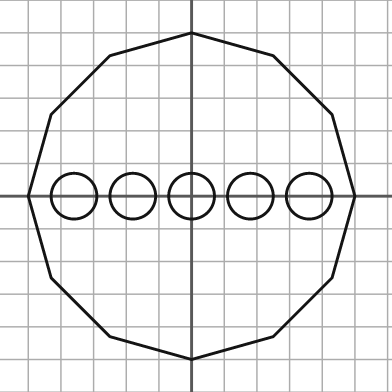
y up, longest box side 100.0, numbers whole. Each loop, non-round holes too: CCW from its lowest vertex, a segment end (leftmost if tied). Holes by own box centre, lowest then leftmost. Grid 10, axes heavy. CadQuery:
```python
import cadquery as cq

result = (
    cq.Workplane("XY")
    .moveTo(0.0, -50.0)
    .lineTo(25.0, -43.0)
    .lineTo(43.0, -25.0)
    .lineTo(50.0, 0.0)
    .lineTo(43.0, 25.0)
    .lineTo(25.0, 43.0)
    .lineTo(0.0, 50.0)
    .lineTo(-25.0, 43.0)
    .lineTo(-43.0, 25.0)
    .lineTo(-50.0, 0.0)
    .lineTo(-43.0, -25.0)
    .lineTo(-25.0, -43.0)
    .close()
    .moveTo(-36.0, 0.0)
    .circle(7.0)
    .moveTo(-18.0, 0.0)
    .circle(7.0)
    .moveTo(0.0, 0.0)
    .circle(7.0)
    .moveTo(18.0, 0.0)
    .circle(7.0)
    .moveTo(36.0, 0.0)
    .circle(7.0)
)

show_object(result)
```